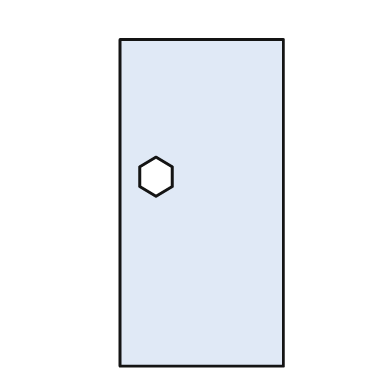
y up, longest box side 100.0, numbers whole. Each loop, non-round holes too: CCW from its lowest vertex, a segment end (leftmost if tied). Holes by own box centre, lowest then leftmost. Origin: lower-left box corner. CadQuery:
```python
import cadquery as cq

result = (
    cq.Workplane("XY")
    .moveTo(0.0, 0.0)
    .lineTo(50.0, 0.0)
    .lineTo(50.0, 100.0)
    .lineTo(0.0, 100.0)
    .close()
    .moveTo(11.0, 52.0)
    .lineTo(16.0, 55.0)
    .lineTo(16.0, 61.0)
    .lineTo(11.0, 64.0)
    .lineTo(6.0, 61.0)
    .lineTo(6.0, 55.0)
    .close()
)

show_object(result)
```